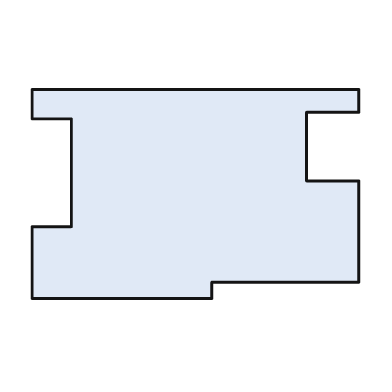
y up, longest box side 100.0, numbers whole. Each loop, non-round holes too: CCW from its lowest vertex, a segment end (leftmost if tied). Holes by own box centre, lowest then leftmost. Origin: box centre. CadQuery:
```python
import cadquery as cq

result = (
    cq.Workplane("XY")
    .moveTo(-50.0, -32.0)
    .lineTo(5.0, -32.0)
    .lineTo(5.0, -27.0)
    .lineTo(50.0, -27.0)
    .lineTo(50.0, 4.0)
    .lineTo(34.0, 4.0)
    .lineTo(34.0, 25.0)
    .lineTo(50.0, 25.0)
    .lineTo(50.0, 32.0)
    .lineTo(-50.0, 32.0)
    .lineTo(-50.0, 23.0)
    .lineTo(-38.0, 23.0)
    .lineTo(-38.0, -10.0)
    .lineTo(-50.0, -10.0)
    .close()
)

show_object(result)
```